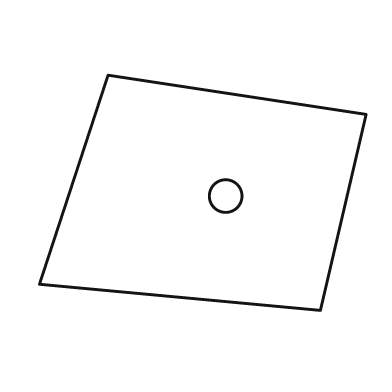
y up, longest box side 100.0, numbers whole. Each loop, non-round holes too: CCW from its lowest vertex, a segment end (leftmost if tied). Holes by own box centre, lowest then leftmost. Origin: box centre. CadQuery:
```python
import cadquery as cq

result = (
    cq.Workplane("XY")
    .moveTo(36.0, -36.0)
    .lineTo(50.0, 24.0)
    .lineTo(-29.0, 36.0)
    .lineTo(-50.0, -28.0)
    .close()
    .moveTo(7.0, -1.0)
    .circle(5.0)
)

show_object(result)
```